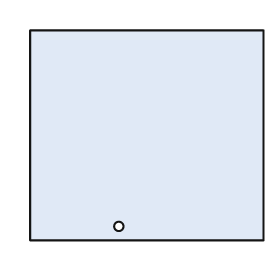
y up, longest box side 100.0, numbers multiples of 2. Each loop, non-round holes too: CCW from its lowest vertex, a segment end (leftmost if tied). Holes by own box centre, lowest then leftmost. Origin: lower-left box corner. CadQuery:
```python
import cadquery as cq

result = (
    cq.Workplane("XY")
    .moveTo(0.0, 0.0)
    .lineTo(100.0, 0.0)
    .lineTo(100.0, 90.0)
    .lineTo(0.0, 90.0)
    .close()
    .moveTo(38.0, 6.0)
    .circle(2.0)
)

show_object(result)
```